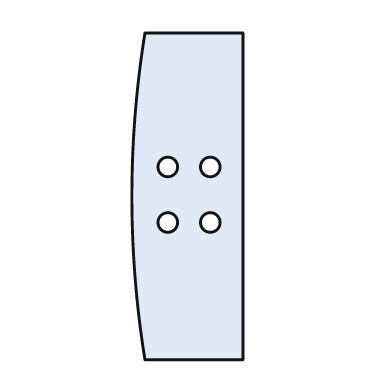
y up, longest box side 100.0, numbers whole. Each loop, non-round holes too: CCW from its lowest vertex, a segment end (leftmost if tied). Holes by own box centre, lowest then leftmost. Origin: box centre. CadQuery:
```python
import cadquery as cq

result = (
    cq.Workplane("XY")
    .moveTo(-13.0, -50.0)
    .lineTo(17.0, -50.0)
    .lineTo(17.0, 50.0)
    .lineTo(-13.0, 50.0)
    .threePointArc((-17.0, 0.0), (-13.0, -50.0))
    .close()
    .moveTo(-6.0, -8.0)
    .circle(3.0)
    .moveTo(7.0, -8.0)
    .circle(3.0)
    .moveTo(-6.0, 9.0)
    .circle(3.0)
    .moveTo(7.0, 9.0)
    .circle(3.0)
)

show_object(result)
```